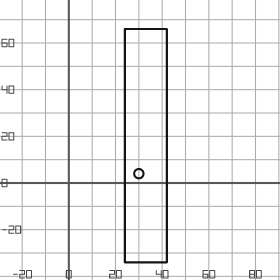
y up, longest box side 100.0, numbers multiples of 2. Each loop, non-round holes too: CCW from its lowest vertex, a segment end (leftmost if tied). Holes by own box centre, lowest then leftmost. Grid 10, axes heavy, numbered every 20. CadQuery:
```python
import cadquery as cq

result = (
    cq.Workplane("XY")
    .moveTo(24.0, -34.0)
    .lineTo(42.0, -34.0)
    .lineTo(42.0, 66.0)
    .lineTo(24.0, 66.0)
    .close()
    .moveTo(30.0, 4.0)
    .circle(2.0)
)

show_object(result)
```